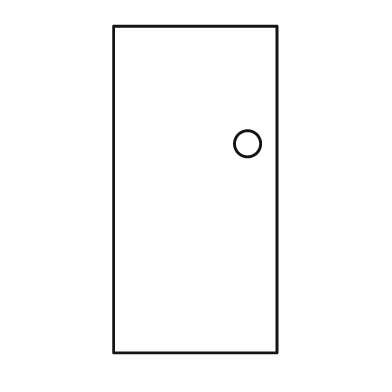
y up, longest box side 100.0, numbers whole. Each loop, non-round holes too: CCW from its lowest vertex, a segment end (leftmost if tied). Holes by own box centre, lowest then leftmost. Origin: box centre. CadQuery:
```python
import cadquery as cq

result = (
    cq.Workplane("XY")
    .moveTo(-25.0, -50.0)
    .lineTo(25.0, -50.0)
    .lineTo(25.0, 50.0)
    .lineTo(-25.0, 50.0)
    .close()
    .moveTo(16.0, 14.0)
    .circle(4.0)
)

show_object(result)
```